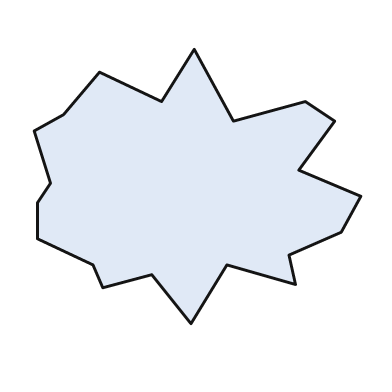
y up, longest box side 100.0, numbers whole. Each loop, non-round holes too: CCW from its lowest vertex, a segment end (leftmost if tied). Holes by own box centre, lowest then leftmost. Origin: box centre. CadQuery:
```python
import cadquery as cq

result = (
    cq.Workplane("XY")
    .moveTo(-2.0, -42.0)
    .lineTo(9.0, -24.0)
    .lineTo(30.0, -30.0)
    .lineTo(28.0, -21.0)
    .lineTo(44.0, -14.0)
    .lineTo(50.0, -3.0)
    .lineTo(31.0, 5.0)
    .lineTo(42.0, 20.0)
    .lineTo(33.0, 26.0)
    .lineTo(11.0, 20.0)
    .lineTo(-1.0, 42.0)
    .lineTo(-11.0, 26.0)
    .lineTo(-30.0, 35.0)
    .lineTo(-41.0, 22.0)
    .lineTo(-50.0, 17.0)
    .lineTo(-45.0, 1.0)
    .lineTo(-49.0, -5.0)
    .lineTo(-49.0, -16.0)
    .lineTo(-32.0, -24.0)
    .lineTo(-29.0, -31.0)
    .lineTo(-14.0, -27.0)
    .close()
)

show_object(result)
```